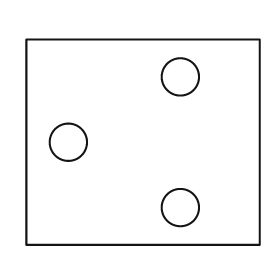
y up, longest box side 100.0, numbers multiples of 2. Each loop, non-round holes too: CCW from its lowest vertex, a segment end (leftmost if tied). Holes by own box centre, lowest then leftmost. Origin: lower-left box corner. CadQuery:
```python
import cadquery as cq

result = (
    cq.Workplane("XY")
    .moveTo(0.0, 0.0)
    .lineTo(100.0, 0.0)
    .lineTo(100.0, 88.0)
    .lineTo(0.0, 88.0)
    .close()
    .moveTo(66.0, 16.0)
    .circle(8.0)
    .moveTo(18.0, 44.0)
    .circle(8.0)
    .moveTo(66.0, 72.0)
    .circle(8.0)
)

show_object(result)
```